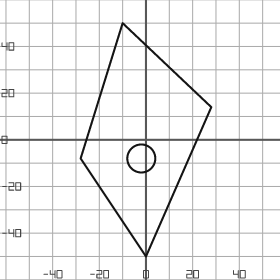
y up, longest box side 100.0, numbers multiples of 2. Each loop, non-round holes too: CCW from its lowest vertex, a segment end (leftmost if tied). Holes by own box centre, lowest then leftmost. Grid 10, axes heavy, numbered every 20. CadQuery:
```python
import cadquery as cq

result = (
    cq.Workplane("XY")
    .moveTo(0.0, -50.0)
    .lineTo(28.0, 14.0)
    .lineTo(-10.0, 50.0)
    .lineTo(-28.0, -8.0)
    .close()
    .moveTo(-2.0, -8.0)
    .circle(6.0)
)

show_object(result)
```